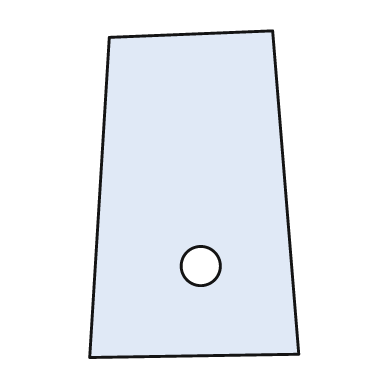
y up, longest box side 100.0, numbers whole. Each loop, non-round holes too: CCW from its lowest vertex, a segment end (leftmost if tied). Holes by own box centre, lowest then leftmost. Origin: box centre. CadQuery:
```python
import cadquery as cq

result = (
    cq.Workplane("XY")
    .moveTo(-32.0, -50.0)
    .lineTo(32.0, -49.0)
    .lineTo(24.0, 50.0)
    .lineTo(-26.0, 48.0)
    .close()
    .moveTo(2.0, -22.0)
    .circle(6.0)
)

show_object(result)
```